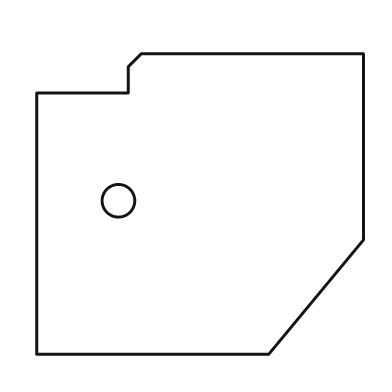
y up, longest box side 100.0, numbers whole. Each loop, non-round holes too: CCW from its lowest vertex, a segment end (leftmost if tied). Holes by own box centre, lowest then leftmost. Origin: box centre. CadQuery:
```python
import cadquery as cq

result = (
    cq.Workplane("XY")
    .moveTo(-50.0, -46.0)
    .lineTo(21.0, -46.0)
    .lineTo(50.0, -11.0)
    .lineTo(50.0, 46.0)
    .lineTo(-18.0, 46.0)
    .lineTo(-22.0, 42.0)
    .lineTo(-22.0, 34.0)
    .lineTo(-50.0, 34.0)
    .close()
    .moveTo(-25.0, 1.0)
    .circle(5.0)
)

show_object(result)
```